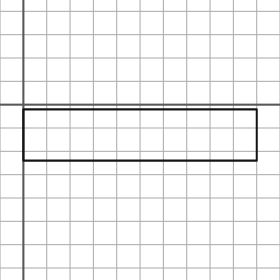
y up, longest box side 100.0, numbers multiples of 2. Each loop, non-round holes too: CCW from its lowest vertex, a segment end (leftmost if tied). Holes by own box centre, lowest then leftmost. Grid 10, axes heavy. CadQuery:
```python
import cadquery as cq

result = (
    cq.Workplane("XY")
    .moveTo(0.0, -24.0)
    .lineTo(100.0, -24.0)
    .lineTo(100.0, -2.0)
    .lineTo(0.0, -2.0)
    .close()
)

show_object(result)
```